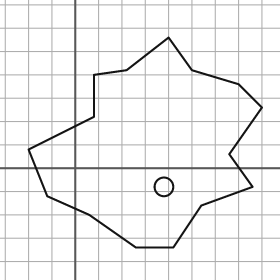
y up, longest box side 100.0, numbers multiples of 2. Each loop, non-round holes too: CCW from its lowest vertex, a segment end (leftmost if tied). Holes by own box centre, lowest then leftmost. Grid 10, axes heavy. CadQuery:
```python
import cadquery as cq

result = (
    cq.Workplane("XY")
    .moveTo(26.0, -34.0)
    .lineTo(42.0, -34.0)
    .lineTo(54.0, -16.0)
    .lineTo(76.0, -8.0)
    .lineTo(66.0, 6.0)
    .lineTo(80.0, 26.0)
    .lineTo(70.0, 36.0)
    .lineTo(50.0, 42.0)
    .lineTo(40.0, 56.0)
    .lineTo(22.0, 42.0)
    .lineTo(8.0, 40.0)
    .lineTo(8.0, 22.0)
    .lineTo(-20.0, 8.0)
    .lineTo(-12.0, -12.0)
    .lineTo(6.0, -20.0)
    .close()
    .moveTo(38.0, -8.0)
    .circle(4.0)
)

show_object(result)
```